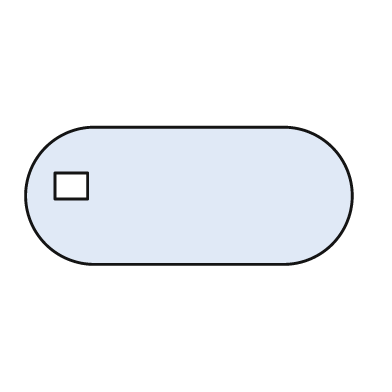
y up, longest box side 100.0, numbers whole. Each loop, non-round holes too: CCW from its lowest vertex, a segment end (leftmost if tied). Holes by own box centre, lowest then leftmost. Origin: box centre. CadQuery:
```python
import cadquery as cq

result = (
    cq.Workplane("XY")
    .moveTo(-29.0, -21.0)
    .lineTo(29.0, -21.0)
    .threePointArc((50.0, 0.0), (29.0, 21.0))
    .lineTo(-29.0, 21.0)
    .threePointArc((-50.0, 0.0), (-29.0, -21.0))
    .close()
    .moveTo(-41.0, -1.0)
    .lineTo(-31.0, -1.0)
    .lineTo(-31.0, 7.0)
    .lineTo(-41.0, 7.0)
    .close()
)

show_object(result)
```